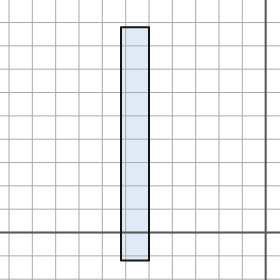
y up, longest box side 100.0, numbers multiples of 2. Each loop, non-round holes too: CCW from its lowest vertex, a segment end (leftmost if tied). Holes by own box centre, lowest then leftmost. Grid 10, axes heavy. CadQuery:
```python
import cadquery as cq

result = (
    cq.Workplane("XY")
    .moveTo(-62.0, -12.0)
    .lineTo(-50.0, -12.0)
    .lineTo(-50.0, 88.0)
    .lineTo(-62.0, 88.0)
    .close()
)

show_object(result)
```